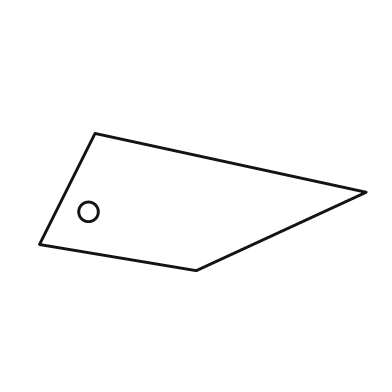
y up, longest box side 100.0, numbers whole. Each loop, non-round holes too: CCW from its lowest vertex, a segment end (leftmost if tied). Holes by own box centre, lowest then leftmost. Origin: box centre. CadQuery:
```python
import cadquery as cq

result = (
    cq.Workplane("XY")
    .moveTo(-2.0, -21.0)
    .lineTo(50.0, 3.0)
    .lineTo(-33.0, 21.0)
    .lineTo(-50.0, -13.0)
    .close()
    .moveTo(-35.0, -3.0)
    .circle(3.0)
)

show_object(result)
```